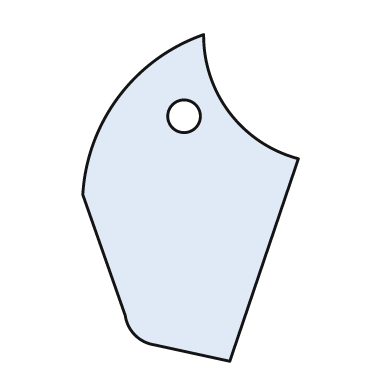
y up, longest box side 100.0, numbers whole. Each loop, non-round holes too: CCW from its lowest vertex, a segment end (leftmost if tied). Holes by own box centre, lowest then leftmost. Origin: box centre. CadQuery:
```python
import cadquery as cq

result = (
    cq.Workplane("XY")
    .moveTo(12.0, -50.0)
    .lineTo(33.0, 12.0)
    .threePointArc((12.0, 26.0), (4.0, 50.0))
    .threePointArc((-22.0, 31.0), (-33.0, 1.0))
    .lineTo(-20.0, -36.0)
    .threePointArc((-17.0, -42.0), (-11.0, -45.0))
    .close()
    .moveTo(-2.0, 25.0)
    .circle(5.0)
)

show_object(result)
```